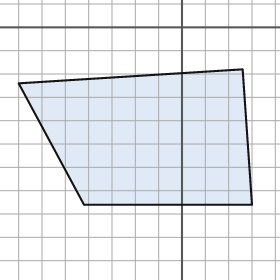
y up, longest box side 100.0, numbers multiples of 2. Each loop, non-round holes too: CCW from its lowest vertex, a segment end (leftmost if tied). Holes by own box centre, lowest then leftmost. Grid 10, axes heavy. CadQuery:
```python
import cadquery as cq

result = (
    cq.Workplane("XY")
    .moveTo(-42.0, -76.0)
    .lineTo(30.0, -76.0)
    .lineTo(26.0, -18.0)
    .lineTo(-70.0, -24.0)
    .close()
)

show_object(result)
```